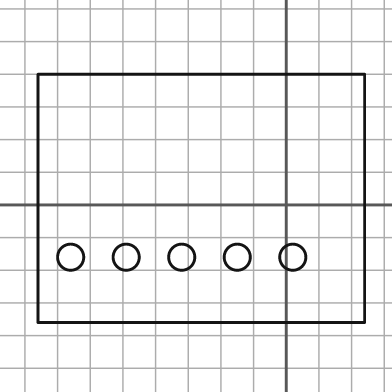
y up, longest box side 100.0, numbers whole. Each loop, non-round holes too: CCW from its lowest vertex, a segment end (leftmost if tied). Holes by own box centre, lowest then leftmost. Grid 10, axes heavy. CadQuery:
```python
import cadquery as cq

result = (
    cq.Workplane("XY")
    .moveTo(-76.0, -36.0)
    .lineTo(24.0, -36.0)
    .lineTo(24.0, 40.0)
    .lineTo(-76.0, 40.0)
    .close()
    .moveTo(-66.0, -16.0)
    .circle(4.0)
    .moveTo(-49.0, -16.0)
    .circle(4.0)
    .moveTo(-32.0, -16.0)
    .circle(4.0)
    .moveTo(-15.0, -16.0)
    .circle(4.0)
    .moveTo(2.0, -16.0)
    .circle(4.0)
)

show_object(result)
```